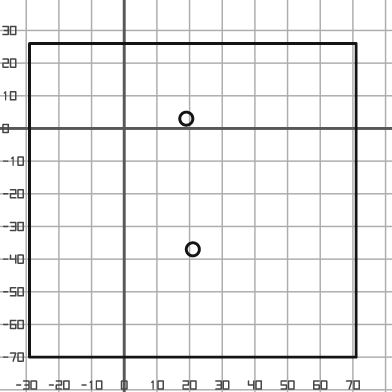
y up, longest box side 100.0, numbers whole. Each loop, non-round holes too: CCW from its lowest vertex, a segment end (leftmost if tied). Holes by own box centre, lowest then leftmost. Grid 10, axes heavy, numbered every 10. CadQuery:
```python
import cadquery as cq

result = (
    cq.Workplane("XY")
    .moveTo(-29.0, -70.0)
    .lineTo(71.0, -70.0)
    .lineTo(71.0, 26.0)
    .lineTo(-29.0, 26.0)
    .close()
    .moveTo(21.0, -37.0)
    .circle(2.0)
    .moveTo(19.0, 3.0)
    .circle(2.0)
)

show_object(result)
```